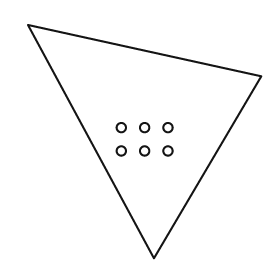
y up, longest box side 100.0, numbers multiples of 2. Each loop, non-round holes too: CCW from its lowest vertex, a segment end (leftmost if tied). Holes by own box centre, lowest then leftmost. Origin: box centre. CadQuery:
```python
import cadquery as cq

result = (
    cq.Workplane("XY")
    .moveTo(4.0, -50.0)
    .lineTo(50.0, 28.0)
    .lineTo(-50.0, 50.0)
    .close()
    .moveTo(-10.0, -4.0)
    .circle(2.0)
    .moveTo(0.0, -4.0)
    .circle(2.0)
    .moveTo(10.0, -4.0)
    .circle(2.0)
    .moveTo(-10.0, 6.0)
    .circle(2.0)
    .moveTo(0.0, 6.0)
    .circle(2.0)
    .moveTo(10.0, 6.0)
    .circle(2.0)
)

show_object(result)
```